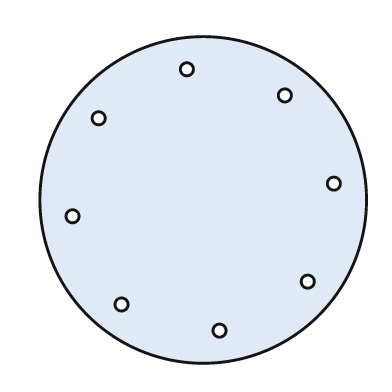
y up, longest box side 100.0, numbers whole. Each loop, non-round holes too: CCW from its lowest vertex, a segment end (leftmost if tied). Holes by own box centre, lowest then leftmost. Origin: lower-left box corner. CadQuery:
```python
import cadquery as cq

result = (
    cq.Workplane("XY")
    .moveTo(50.0, 50.0)
    .circle(50.0)
    .moveTo(55.0, 10.0)
    .circle(2.0)
    .moveTo(25.0, 18.0)
    .circle(2.0)
    .moveTo(82.0, 25.0)
    .circle(2.0)
    .moveTo(10.0, 45.0)
    .circle(2.0)
    .moveTo(90.0, 55.0)
    .circle(2.0)
    .moveTo(18.0, 75.0)
    .circle(2.0)
    .moveTo(75.0, 82.0)
    .circle(2.0)
    .moveTo(45.0, 90.0)
    .circle(2.0)
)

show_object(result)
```